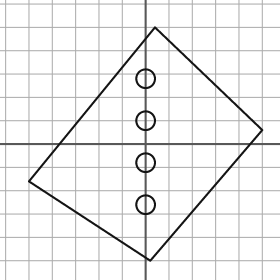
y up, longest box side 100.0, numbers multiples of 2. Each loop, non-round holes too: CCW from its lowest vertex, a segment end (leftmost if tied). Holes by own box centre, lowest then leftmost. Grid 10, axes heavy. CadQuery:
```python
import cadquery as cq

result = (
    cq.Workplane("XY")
    .moveTo(2.0, -50.0)
    .lineTo(50.0, 6.0)
    .lineTo(4.0, 50.0)
    .lineTo(-50.0, -16.0)
    .close()
    .moveTo(0.0, -26.0)
    .circle(4.0)
    .moveTo(0.0, -8.0)
    .circle(4.0)
    .moveTo(0.0, 10.0)
    .circle(4.0)
    .moveTo(0.0, 28.0)
    .circle(4.0)
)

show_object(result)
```